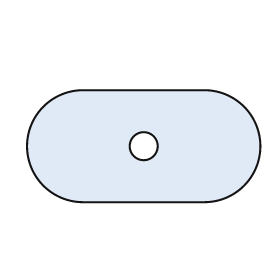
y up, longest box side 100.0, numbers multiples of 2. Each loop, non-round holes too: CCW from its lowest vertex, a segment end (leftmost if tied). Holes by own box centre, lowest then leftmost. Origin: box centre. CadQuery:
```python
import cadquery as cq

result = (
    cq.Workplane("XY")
    .moveTo(-26.0, -24.0)
    .lineTo(26.0, -24.0)
    .threePointArc((50.0, 0.0), (26.0, 24.0))
    .lineTo(-26.0, 24.0)
    .threePointArc((-50.0, 0.0), (-26.0, -24.0))
    .close()
    .moveTo(0.0, 0.0)
    .circle(6.0)
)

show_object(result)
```